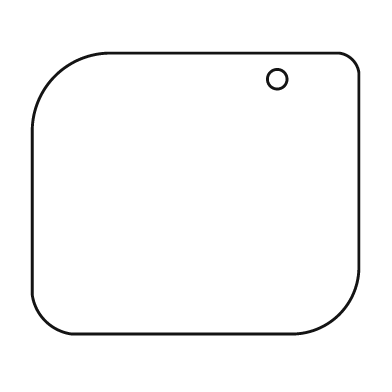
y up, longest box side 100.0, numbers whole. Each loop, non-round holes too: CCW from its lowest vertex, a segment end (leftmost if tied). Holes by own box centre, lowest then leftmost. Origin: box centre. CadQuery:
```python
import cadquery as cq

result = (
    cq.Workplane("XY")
    .moveTo(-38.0, -43.0)
    .lineTo(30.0, -43.0)
    .threePointArc((44.0, -37.0), (50.0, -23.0))
    .lineTo(50.0, 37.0)
    .threePointArc((48.0, 41.0), (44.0, 43.0))
    .lineTo(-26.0, 43.0)
    .threePointArc((-43.0, 36.0), (-50.0, 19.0))
    .lineTo(-50.0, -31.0)
    .threePointArc((-46.0, -39.0), (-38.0, -43.0))
    .close()
    .moveTo(25.0, 35.0)
    .circle(3.0)
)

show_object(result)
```